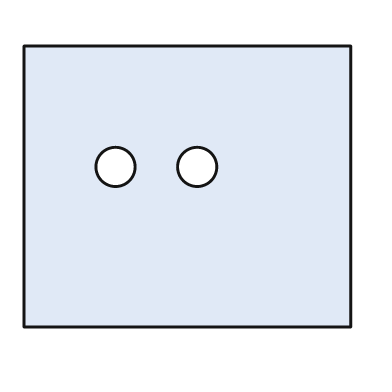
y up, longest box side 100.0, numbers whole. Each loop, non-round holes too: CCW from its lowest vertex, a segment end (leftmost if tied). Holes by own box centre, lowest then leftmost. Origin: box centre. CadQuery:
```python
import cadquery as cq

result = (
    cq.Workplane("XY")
    .moveTo(-50.0, -43.0)
    .lineTo(50.0, -43.0)
    .lineTo(50.0, 43.0)
    .lineTo(-50.0, 43.0)
    .close()
    .moveTo(-22.0, 6.0)
    .circle(6.0)
    .moveTo(3.0, 6.0)
    .circle(6.0)
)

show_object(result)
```